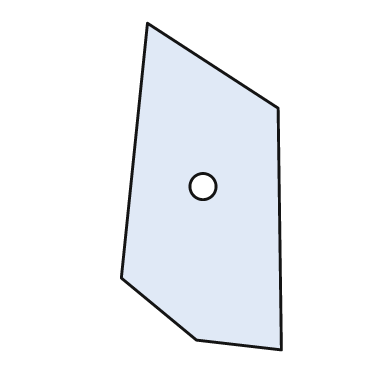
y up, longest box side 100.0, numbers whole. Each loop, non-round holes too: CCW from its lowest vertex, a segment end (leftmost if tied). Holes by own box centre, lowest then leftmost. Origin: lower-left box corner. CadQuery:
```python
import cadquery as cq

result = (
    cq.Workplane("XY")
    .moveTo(49.0, 0.0)
    .lineTo(48.0, 74.0)
    .lineTo(8.0, 100.0)
    .lineTo(0.0, 22.0)
    .lineTo(23.0, 3.0)
    .close()
    .moveTo(25.0, 50.0)
    .circle(4.0)
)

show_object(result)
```